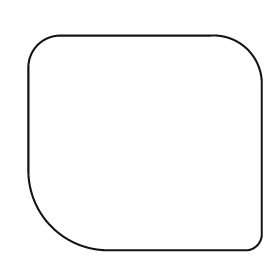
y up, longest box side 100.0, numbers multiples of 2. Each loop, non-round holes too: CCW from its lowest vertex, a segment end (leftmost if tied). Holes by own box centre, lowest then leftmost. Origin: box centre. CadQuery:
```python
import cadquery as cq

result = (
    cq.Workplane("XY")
    .moveTo(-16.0, -46.0)
    .lineTo(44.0, -46.0)
    .threePointArc((48.0, -44.0), (50.0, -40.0))
    .lineTo(50.0, 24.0)
    .threePointArc((44.0, 40.0), (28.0, 46.0))
    .lineTo(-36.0, 46.0)
    .threePointArc((-46.0, 42.0), (-50.0, 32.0))
    .lineTo(-50.0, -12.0)
    .threePointArc((-40.0, -36.0), (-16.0, -46.0))
    .close()
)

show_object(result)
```